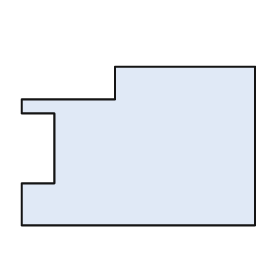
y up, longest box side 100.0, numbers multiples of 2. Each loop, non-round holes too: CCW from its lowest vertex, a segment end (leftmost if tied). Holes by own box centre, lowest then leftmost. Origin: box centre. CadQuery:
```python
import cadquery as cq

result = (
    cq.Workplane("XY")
    .moveTo(-50.0, -34.0)
    .lineTo(50.0, -34.0)
    .lineTo(50.0, 34.0)
    .lineTo(-10.0, 34.0)
    .lineTo(-10.0, 20.0)
    .lineTo(-50.0, 20.0)
    .lineTo(-50.0, 14.0)
    .lineTo(-36.0, 14.0)
    .lineTo(-36.0, -16.0)
    .lineTo(-50.0, -16.0)
    .close()
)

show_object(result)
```